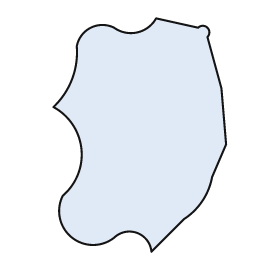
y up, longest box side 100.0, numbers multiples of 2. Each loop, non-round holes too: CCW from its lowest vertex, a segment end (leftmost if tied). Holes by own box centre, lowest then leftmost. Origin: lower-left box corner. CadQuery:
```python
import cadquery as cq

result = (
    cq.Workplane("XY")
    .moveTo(42.0, 0.0)
    .lineTo(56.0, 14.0)
    .threePointArc((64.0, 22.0), (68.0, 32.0))
    .lineTo(74.0, 46.0)
    .lineTo(72.0, 70.0)
    .lineTo(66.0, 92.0)
    .threePointArc((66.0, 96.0), (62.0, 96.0))
    .lineTo(44.0, 100.0)
    .threePointArc((36.0, 94.0), (26.0, 96.0))
    .threePointArc((16.0, 96.0), (10.0, 88.0))
    .threePointArc((8.0, 74.0), (0.0, 62.0))
    .threePointArc((12.0, 44.0), (4.0, 24.0))
    .threePointArc((8.0, 6.0), (26.0, 6.0))
    .threePointArc((36.0, 8.0), (42.0, 0.0))
    .close()
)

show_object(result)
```